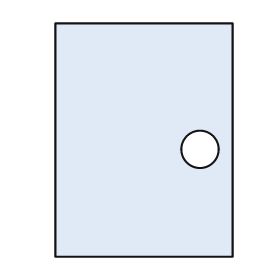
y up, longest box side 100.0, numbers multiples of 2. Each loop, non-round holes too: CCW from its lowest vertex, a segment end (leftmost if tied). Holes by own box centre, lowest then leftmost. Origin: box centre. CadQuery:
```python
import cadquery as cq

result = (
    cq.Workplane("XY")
    .moveTo(-38.0, -50.0)
    .lineTo(38.0, -50.0)
    .lineTo(38.0, 50.0)
    .lineTo(-38.0, 50.0)
    .close()
    .moveTo(24.0, -4.0)
    .circle(8.0)
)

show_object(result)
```